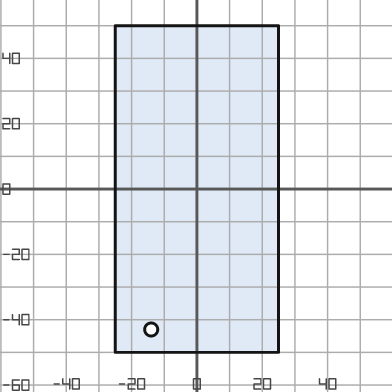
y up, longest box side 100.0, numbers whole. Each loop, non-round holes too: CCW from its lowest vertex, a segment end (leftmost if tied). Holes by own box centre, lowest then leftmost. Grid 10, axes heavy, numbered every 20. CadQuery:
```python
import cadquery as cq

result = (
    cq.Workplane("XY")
    .moveTo(-25.0, -50.0)
    .lineTo(25.0, -50.0)
    .lineTo(25.0, 50.0)
    .lineTo(-25.0, 50.0)
    .close()
    .moveTo(-14.0, -43.0)
    .circle(2.0)
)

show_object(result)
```